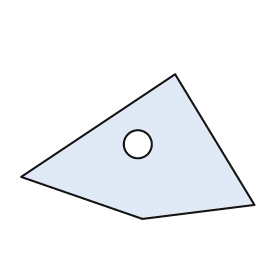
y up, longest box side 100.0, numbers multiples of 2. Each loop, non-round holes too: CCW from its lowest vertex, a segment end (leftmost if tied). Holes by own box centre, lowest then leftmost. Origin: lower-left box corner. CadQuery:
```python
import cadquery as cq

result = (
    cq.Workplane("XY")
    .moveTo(52.0, 0.0)
    .lineTo(100.0, 6.0)
    .lineTo(66.0, 62.0)
    .lineTo(0.0, 18.0)
    .close()
    .moveTo(50.0, 32.0)
    .circle(6.0)
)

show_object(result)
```